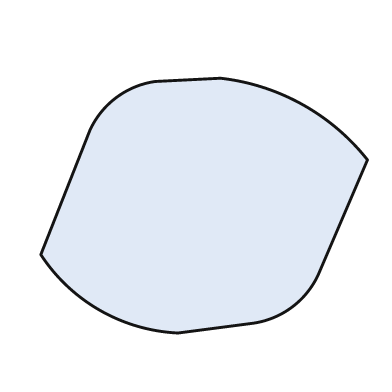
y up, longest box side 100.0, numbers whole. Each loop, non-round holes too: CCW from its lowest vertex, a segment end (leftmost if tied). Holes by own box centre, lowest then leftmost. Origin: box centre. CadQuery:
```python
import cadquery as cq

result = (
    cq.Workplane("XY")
    .moveTo(-8.0, -39.0)
    .lineTo(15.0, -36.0)
    .threePointArc((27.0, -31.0), (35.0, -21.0))
    .lineTo(50.0, 14.0)
    .threePointArc((30.0, 31.0), (5.0, 39.0))
    .lineTo(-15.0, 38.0)
    .threePointArc((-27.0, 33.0), (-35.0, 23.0))
    .lineTo(-50.0, -15.0)
    .threePointArc((-32.0, -32.0), (-8.0, -39.0))
    .close()
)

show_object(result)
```